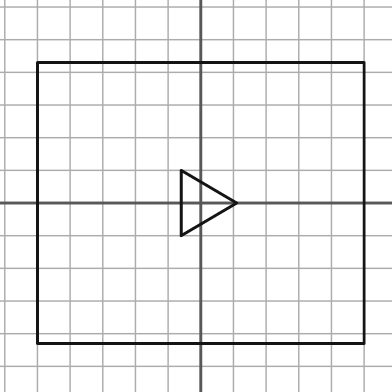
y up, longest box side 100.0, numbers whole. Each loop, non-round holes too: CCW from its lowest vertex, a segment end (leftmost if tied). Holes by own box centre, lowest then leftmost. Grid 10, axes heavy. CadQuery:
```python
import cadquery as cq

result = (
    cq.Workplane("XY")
    .moveTo(-50.0, -43.0)
    .lineTo(50.0, -43.0)
    .lineTo(50.0, 43.0)
    .lineTo(-50.0, 43.0)
    .close()
    .moveTo(-6.0, -10.0)
    .lineTo(11.0, 0.0)
    .lineTo(-6.0, 10.0)
    .close()
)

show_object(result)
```